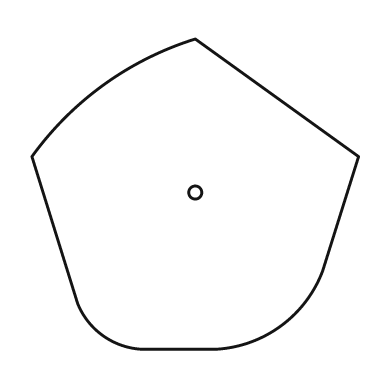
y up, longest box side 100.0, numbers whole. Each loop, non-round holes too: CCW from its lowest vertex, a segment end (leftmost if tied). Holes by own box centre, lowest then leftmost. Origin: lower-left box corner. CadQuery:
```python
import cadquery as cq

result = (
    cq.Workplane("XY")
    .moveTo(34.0, 0.0)
    .lineTo(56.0, 0.0)
    .threePointArc((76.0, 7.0), (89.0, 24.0))
    .lineTo(100.0, 59.0)
    .lineTo(50.0, 95.0)
    .threePointArc((22.0, 81.0), (0.0, 59.0))
    .lineTo(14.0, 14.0)
    .threePointArc((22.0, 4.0), (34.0, 0.0))
    .close()
    .moveTo(50.0, 48.0)
    .circle(2.0)
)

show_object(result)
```